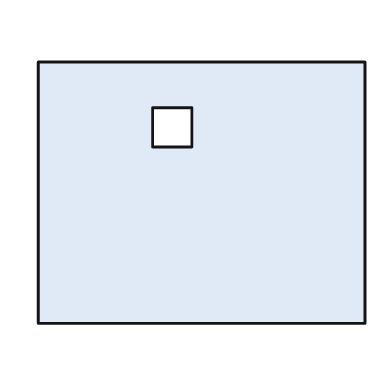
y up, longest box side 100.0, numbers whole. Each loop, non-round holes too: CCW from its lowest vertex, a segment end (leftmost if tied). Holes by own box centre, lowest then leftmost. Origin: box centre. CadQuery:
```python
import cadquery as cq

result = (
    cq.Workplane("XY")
    .moveTo(-50.0, -40.0)
    .lineTo(50.0, -40.0)
    .lineTo(50.0, 40.0)
    .lineTo(-50.0, 40.0)
    .close()
    .moveTo(-15.0, 14.0)
    .lineTo(-3.0, 14.0)
    .lineTo(-3.0, 26.0)
    .lineTo(-15.0, 26.0)
    .close()
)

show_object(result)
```